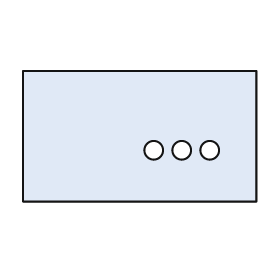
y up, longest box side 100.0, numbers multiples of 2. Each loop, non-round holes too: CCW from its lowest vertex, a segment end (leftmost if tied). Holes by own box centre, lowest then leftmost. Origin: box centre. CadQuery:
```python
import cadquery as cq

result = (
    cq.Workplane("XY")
    .moveTo(-50.0, -28.0)
    .lineTo(50.0, -28.0)
    .lineTo(50.0, 28.0)
    .lineTo(-50.0, 28.0)
    .close()
    .moveTo(6.0, -6.0)
    .circle(4.0)
    .moveTo(18.0, -6.0)
    .circle(4.0)
    .moveTo(30.0, -6.0)
    .circle(4.0)
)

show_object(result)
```